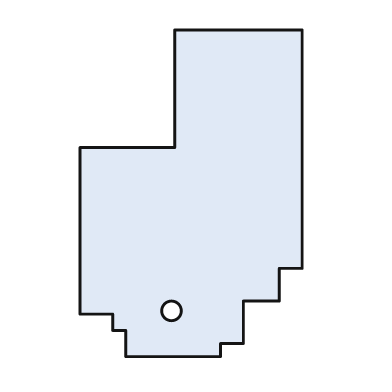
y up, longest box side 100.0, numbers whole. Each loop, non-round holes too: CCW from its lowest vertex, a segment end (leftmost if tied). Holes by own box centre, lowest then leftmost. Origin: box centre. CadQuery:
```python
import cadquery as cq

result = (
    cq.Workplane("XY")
    .moveTo(-20.0, -50.0)
    .lineTo(9.0, -50.0)
    .lineTo(9.0, -46.0)
    .lineTo(16.0, -46.0)
    .lineTo(16.0, -33.0)
    .lineTo(27.0, -33.0)
    .lineTo(27.0, -23.0)
    .lineTo(34.0, -23.0)
    .lineTo(34.0, 50.0)
    .lineTo(-5.0, 50.0)
    .lineTo(-5.0, 14.0)
    .lineTo(-34.0, 14.0)
    .lineTo(-34.0, -37.0)
    .lineTo(-24.0, -37.0)
    .lineTo(-24.0, -42.0)
    .lineTo(-20.0, -42.0)
    .close()
    .moveTo(-6.0, -36.0)
    .circle(3.0)
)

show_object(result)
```